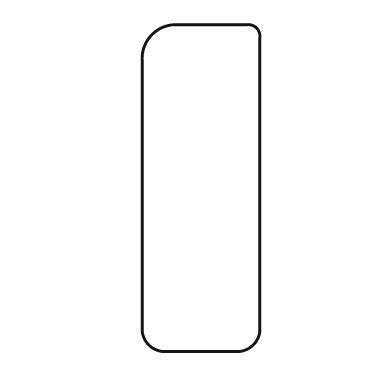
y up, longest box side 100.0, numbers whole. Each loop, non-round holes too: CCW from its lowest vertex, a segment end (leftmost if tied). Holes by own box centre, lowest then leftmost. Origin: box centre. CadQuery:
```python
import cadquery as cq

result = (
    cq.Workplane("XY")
    .moveTo(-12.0, -50.0)
    .lineTo(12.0, -50.0)
    .threePointArc((16.0, -48.0), (18.0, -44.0))
    .lineTo(18.0, 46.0)
    .threePointArc((17.0, 49.0), (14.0, 50.0))
    .lineTo(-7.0, 50.0)
    .threePointArc((-15.0, 47.0), (-18.0, 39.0))
    .lineTo(-18.0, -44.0)
    .threePointArc((-16.0, -48.0), (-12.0, -50.0))
    .close()
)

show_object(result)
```